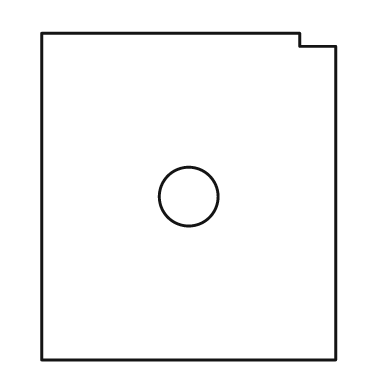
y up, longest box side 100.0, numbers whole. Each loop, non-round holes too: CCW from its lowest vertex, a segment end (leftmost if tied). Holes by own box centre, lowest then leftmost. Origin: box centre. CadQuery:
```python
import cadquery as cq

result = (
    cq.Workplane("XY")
    .moveTo(-45.0, -50.0)
    .lineTo(45.0, -50.0)
    .lineTo(45.0, 46.0)
    .lineTo(34.0, 46.0)
    .lineTo(34.0, 50.0)
    .lineTo(-45.0, 50.0)
    .close()
    .moveTo(0.0, 0.0)
    .circle(9.0)
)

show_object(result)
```